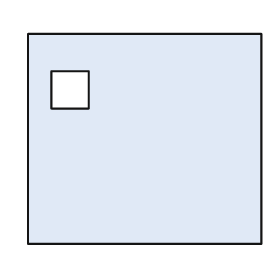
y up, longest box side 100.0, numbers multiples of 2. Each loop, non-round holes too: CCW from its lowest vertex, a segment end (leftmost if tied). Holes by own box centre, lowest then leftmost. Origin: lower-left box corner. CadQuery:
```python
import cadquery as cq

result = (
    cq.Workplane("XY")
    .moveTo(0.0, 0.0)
    .lineTo(100.0, 0.0)
    .lineTo(100.0, 90.0)
    .lineTo(0.0, 90.0)
    .close()
    .moveTo(10.0, 58.0)
    .lineTo(26.0, 58.0)
    .lineTo(26.0, 74.0)
    .lineTo(10.0, 74.0)
    .close()
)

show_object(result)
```